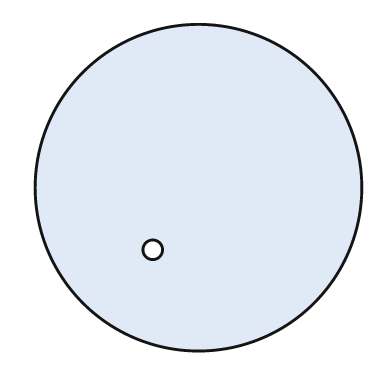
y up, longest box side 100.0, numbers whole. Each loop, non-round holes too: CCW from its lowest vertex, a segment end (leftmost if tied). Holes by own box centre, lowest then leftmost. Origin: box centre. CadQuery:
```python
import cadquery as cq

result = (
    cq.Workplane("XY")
    .moveTo(0.0, 0.0)
    .circle(50.0)
    .moveTo(-14.0, -19.0)
    .circle(3.0)
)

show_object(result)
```